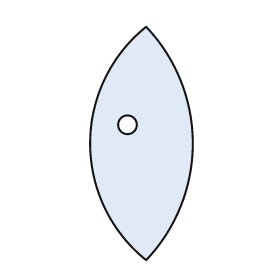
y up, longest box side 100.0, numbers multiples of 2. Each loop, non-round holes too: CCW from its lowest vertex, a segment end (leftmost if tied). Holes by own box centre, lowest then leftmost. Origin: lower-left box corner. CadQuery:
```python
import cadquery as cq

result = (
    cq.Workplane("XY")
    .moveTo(24.0, 0.0)
    .threePointArc((44.0, 50.0), (24.0, 100.0))
    .threePointArc((0.0, 50.0), (24.0, 0.0))
    .close()
    .moveTo(16.0, 58.0)
    .circle(4.0)
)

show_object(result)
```